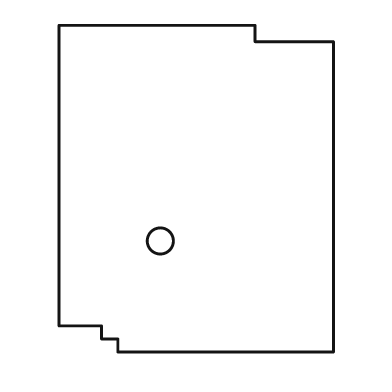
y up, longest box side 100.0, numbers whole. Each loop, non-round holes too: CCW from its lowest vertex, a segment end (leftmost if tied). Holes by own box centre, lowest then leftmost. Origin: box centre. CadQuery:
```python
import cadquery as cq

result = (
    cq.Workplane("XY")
    .moveTo(-24.0, -50.0)
    .lineTo(42.0, -50.0)
    .lineTo(42.0, 45.0)
    .lineTo(18.0, 45.0)
    .lineTo(18.0, 50.0)
    .lineTo(-42.0, 50.0)
    .lineTo(-42.0, -42.0)
    .lineTo(-29.0, -42.0)
    .lineTo(-29.0, -46.0)
    .lineTo(-24.0, -46.0)
    .close()
    .moveTo(-11.0, -16.0)
    .circle(4.0)
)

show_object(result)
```